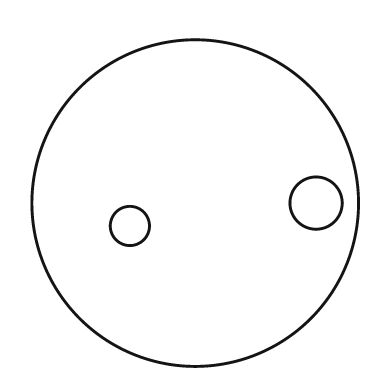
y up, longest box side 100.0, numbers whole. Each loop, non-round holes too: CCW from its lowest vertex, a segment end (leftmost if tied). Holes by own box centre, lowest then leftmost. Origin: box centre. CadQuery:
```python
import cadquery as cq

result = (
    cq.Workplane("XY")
    .moveTo(0.0, 0.0)
    .circle(50.0)
    .moveTo(-20.0, -7.0)
    .circle(6.0)
    .moveTo(37.0, 0.0)
    .circle(8.0)
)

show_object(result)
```